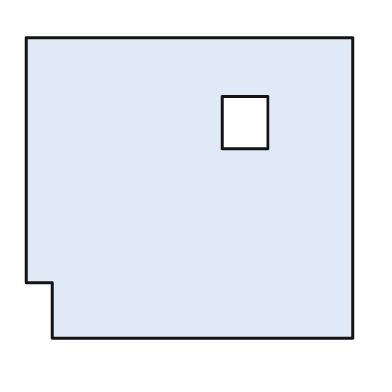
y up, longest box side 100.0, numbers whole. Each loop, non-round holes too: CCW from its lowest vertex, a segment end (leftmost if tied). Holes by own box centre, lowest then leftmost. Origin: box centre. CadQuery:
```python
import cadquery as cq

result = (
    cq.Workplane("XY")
    .moveTo(-42.0, -46.0)
    .lineTo(50.0, -46.0)
    .lineTo(50.0, 46.0)
    .lineTo(-50.0, 46.0)
    .lineTo(-50.0, -29.0)
    .lineTo(-42.0, -29.0)
    .close()
    .moveTo(10.0, 12.0)
    .lineTo(24.0, 12.0)
    .lineTo(24.0, 28.0)
    .lineTo(10.0, 28.0)
    .close()
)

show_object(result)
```